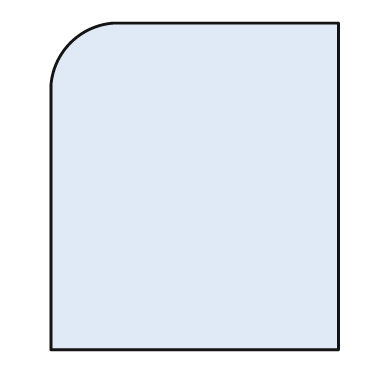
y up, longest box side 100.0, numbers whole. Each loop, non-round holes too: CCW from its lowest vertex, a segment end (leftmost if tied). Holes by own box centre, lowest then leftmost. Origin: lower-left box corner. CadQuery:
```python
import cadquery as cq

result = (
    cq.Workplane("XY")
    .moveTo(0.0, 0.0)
    .lineTo(88.0, 0.0)
    .lineTo(88.0, 100.0)
    .lineTo(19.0, 100.0)
    .threePointArc((6.0, 94.0), (0.0, 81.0))
    .close()
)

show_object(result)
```